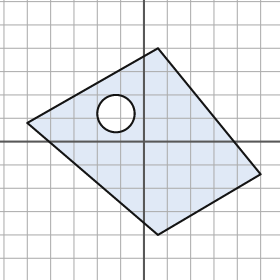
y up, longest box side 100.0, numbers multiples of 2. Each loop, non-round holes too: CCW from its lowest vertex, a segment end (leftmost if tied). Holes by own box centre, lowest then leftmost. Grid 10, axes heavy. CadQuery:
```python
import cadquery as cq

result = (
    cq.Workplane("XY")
    .moveTo(6.0, -40.0)
    .lineTo(50.0, -14.0)
    .lineTo(6.0, 40.0)
    .lineTo(-50.0, 8.0)
    .close()
    .moveTo(-12.0, 12.0)
    .circle(8.0)
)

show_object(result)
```